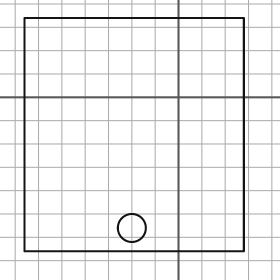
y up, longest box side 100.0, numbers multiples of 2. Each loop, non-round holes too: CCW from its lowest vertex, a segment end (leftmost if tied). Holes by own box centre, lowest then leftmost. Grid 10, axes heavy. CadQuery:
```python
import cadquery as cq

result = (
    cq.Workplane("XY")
    .moveTo(-66.0, -66.0)
    .lineTo(28.0, -66.0)
    .lineTo(28.0, 34.0)
    .lineTo(-66.0, 34.0)
    .close()
    .moveTo(-20.0, -56.0)
    .circle(6.0)
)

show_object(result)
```